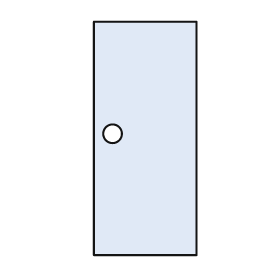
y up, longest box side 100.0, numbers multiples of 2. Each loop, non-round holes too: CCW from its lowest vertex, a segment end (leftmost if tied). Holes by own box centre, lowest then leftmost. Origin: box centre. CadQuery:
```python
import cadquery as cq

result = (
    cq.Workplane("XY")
    .moveTo(-22.0, -50.0)
    .lineTo(22.0, -50.0)
    .lineTo(22.0, 50.0)
    .lineTo(-22.0, 50.0)
    .close()
    .moveTo(-14.0, 2.0)
    .circle(4.0)
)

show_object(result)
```